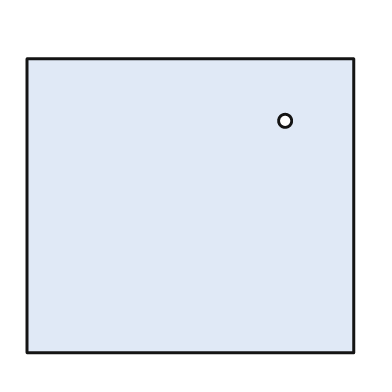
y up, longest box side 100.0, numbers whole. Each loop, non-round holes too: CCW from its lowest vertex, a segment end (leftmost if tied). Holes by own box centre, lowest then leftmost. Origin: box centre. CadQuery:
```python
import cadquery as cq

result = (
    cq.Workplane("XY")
    .moveTo(-50.0, -45.0)
    .lineTo(50.0, -45.0)
    .lineTo(50.0, 45.0)
    .lineTo(-50.0, 45.0)
    .close()
    .moveTo(29.0, 26.0)
    .circle(2.0)
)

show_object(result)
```